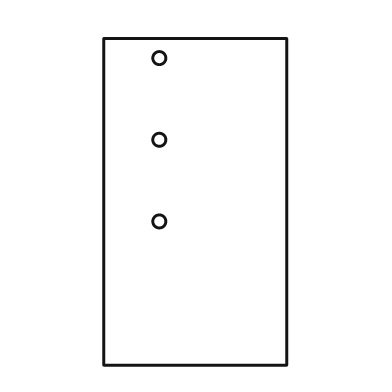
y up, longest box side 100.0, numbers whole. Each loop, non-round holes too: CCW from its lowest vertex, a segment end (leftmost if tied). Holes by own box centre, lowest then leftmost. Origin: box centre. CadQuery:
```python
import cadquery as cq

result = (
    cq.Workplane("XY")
    .moveTo(-28.0, -50.0)
    .lineTo(28.0, -50.0)
    .lineTo(28.0, 50.0)
    .lineTo(-28.0, 50.0)
    .close()
    .moveTo(-11.0, -6.0)
    .circle(2.0)
    .moveTo(-11.0, 19.0)
    .circle(2.0)
    .moveTo(-11.0, 44.0)
    .circle(2.0)
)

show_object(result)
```